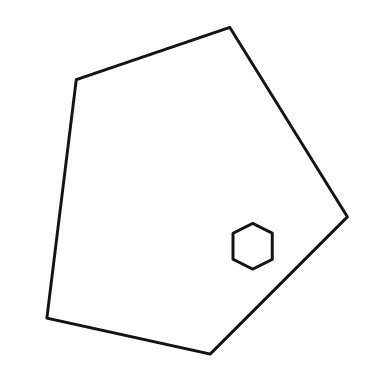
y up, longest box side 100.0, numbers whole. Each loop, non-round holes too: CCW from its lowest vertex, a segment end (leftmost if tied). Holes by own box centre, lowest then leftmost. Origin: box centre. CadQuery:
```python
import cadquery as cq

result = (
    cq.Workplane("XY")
    .moveTo(4.0, -50.0)
    .lineTo(46.0, -8.0)
    .lineTo(10.0, 50.0)
    .lineTo(-37.0, 34.0)
    .lineTo(-46.0, -39.0)
    .close()
    .moveTo(17.0, -24.0)
    .lineTo(23.0, -21.0)
    .lineTo(23.0, -13.0)
    .lineTo(17.0, -10.0)
    .lineTo(11.0, -13.0)
    .lineTo(11.0, -21.0)
    .close()
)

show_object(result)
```